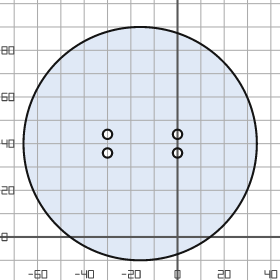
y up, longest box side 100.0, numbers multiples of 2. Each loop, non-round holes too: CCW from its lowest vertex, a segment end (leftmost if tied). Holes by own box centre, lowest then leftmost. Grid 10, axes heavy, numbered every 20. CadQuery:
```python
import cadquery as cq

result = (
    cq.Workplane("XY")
    .moveTo(-16.0, 40.0)
    .circle(50.0)
    .moveTo(-30.0, 36.0)
    .circle(2.0)
    .moveTo(0.0, 36.0)
    .circle(2.0)
    .moveTo(-30.0, 44.0)
    .circle(2.0)
    .moveTo(0.0, 44.0)
    .circle(2.0)
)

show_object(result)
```